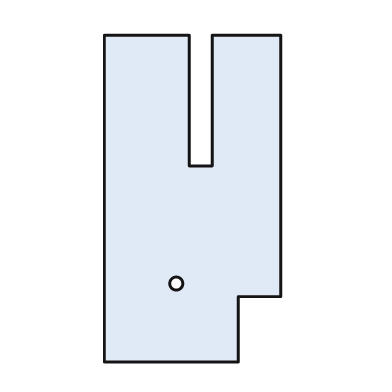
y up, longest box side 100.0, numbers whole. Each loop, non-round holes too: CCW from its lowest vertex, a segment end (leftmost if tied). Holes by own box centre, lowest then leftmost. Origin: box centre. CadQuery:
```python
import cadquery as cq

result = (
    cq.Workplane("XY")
    .moveTo(-27.0, -50.0)
    .lineTo(14.0, -50.0)
    .lineTo(14.0, -30.0)
    .lineTo(27.0, -30.0)
    .lineTo(27.0, 50.0)
    .lineTo(6.0, 50.0)
    .lineTo(6.0, 10.0)
    .lineTo(-1.0, 10.0)
    .lineTo(-1.0, 50.0)
    .lineTo(-27.0, 50.0)
    .close()
    .moveTo(-5.0, -26.0)
    .circle(2.0)
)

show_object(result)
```